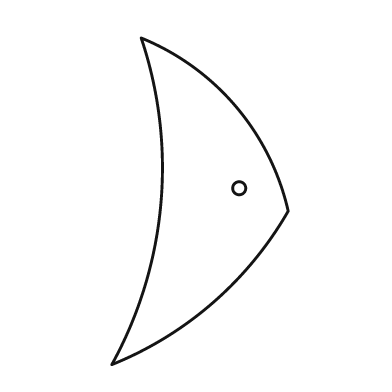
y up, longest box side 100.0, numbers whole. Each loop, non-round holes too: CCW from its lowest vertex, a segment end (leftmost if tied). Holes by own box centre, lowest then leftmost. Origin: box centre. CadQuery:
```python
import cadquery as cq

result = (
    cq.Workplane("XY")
    .moveTo(-27.0, -50.0)
    .threePointArc((4.0, -31.0), (27.0, -3.0))
    .threePointArc((11.0, 29.0), (-18.0, 50.0))
    .threePointArc((-12.0, -1.0), (-27.0, -50.0))
    .close()
    .moveTo(12.0, 4.0)
    .circle(2.0)
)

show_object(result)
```